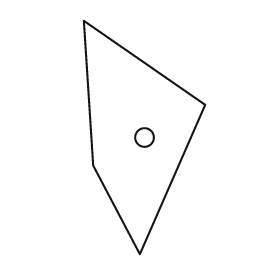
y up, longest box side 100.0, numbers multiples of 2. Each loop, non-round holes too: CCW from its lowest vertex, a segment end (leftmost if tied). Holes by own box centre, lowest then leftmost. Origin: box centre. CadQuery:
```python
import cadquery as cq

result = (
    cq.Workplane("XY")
    .moveTo(-2.0, -50.0)
    .lineTo(26.0, 14.0)
    .lineTo(-26.0, 50.0)
    .lineTo(-22.0, -12.0)
    .close()
    .moveTo(0.0, 0.0)
    .circle(4.0)
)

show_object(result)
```